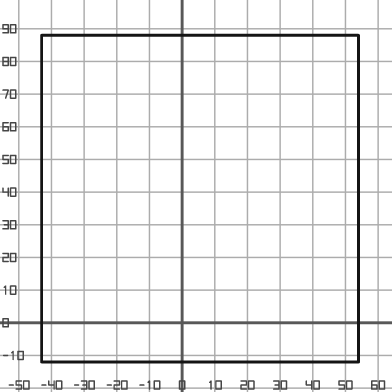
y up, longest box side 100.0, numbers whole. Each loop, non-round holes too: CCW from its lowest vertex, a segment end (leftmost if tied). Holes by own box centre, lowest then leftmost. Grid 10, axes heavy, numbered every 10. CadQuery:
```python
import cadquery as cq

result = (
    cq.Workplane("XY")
    .moveTo(-43.0, -12.0)
    .lineTo(54.0, -12.0)
    .lineTo(54.0, 88.0)
    .lineTo(-43.0, 88.0)
    .close()
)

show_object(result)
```